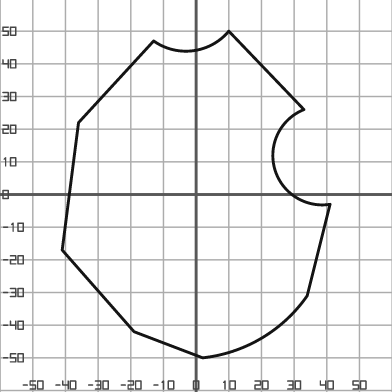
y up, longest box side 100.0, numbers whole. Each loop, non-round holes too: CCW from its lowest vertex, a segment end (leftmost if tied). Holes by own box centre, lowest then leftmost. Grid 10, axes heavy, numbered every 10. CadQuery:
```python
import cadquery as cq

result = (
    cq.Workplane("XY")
    .moveTo(2.0, -50.0)
    .threePointArc((20.0, -44.0), (34.0, -31.0))
    .lineTo(41.0, -3.0)
    .threePointArc((24.0, 8.0), (33.0, 26.0))
    .lineTo(10.0, 50.0)
    .threePointArc((-1.0, 44.0), (-13.0, 47.0))
    .lineTo(-36.0, 22.0)
    .lineTo(-41.0, -17.0)
    .lineTo(-19.0, -42.0)
    .close()
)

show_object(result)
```